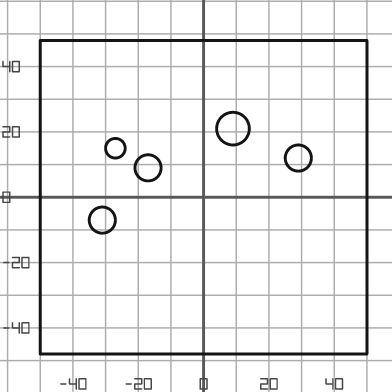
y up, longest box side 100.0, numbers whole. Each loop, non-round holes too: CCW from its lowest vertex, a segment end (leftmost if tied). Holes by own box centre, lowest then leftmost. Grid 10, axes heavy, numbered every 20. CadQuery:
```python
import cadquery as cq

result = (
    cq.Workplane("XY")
    .moveTo(-50.0, -48.0)
    .lineTo(50.0, -48.0)
    .lineTo(50.0, 48.0)
    .lineTo(-50.0, 48.0)
    .close()
    .moveTo(-31.0, -7.0)
    .circle(4.0)
    .moveTo(-17.0, 9.0)
    .circle(4.0)
    .moveTo(29.0, 12.0)
    .circle(4.0)
    .moveTo(-27.0, 15.0)
    .circle(3.0)
    .moveTo(9.0, 21.0)
    .circle(5.0)
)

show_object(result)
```